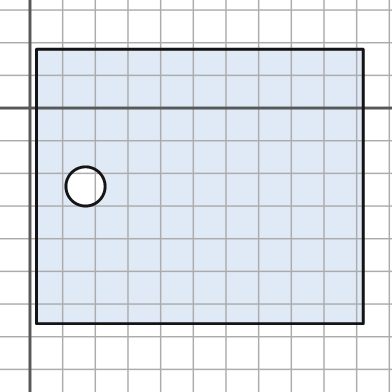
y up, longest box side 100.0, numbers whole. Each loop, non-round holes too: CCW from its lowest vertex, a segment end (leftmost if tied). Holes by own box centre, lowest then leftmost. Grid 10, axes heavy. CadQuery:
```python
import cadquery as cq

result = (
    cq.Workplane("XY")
    .moveTo(2.0, -66.0)
    .lineTo(102.0, -66.0)
    .lineTo(102.0, 18.0)
    .lineTo(2.0, 18.0)
    .close()
    .moveTo(17.0, -24.0)
    .circle(6.0)
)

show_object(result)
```